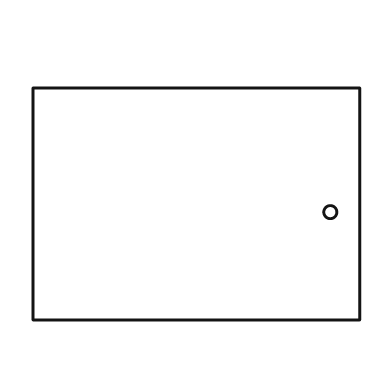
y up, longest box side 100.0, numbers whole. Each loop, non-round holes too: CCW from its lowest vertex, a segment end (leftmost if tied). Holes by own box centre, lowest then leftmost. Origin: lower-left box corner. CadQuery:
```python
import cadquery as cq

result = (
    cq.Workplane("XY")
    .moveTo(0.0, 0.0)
    .lineTo(100.0, 0.0)
    .lineTo(100.0, 71.0)
    .lineTo(0.0, 71.0)
    .close()
    .moveTo(91.0, 33.0)
    .circle(2.0)
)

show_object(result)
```